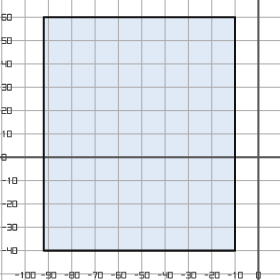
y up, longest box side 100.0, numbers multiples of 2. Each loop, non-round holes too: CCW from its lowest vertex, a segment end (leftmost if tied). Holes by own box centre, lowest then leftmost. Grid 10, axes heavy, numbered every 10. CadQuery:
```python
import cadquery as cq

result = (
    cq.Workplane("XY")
    .moveTo(-92.0, -40.0)
    .lineTo(-10.0, -40.0)
    .lineTo(-10.0, 60.0)
    .lineTo(-92.0, 60.0)
    .close()
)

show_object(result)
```